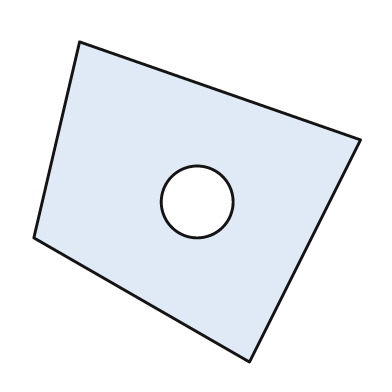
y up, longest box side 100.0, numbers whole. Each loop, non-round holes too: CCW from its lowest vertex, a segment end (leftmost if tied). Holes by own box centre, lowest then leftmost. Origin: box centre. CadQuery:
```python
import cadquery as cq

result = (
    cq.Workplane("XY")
    .moveTo(16.0, -49.0)
    .lineTo(50.0, 19.0)
    .lineTo(-36.0, 49.0)
    .lineTo(-50.0, -11.0)
    .close()
    .moveTo(0.0, 0.0)
    .circle(11.0)
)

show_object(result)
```